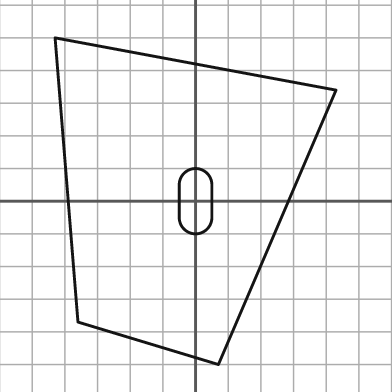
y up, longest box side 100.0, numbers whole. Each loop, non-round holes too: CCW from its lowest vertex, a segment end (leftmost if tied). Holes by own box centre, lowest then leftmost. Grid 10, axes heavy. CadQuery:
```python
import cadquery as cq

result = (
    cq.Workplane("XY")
    .moveTo(7.0, -50.0)
    .lineTo(43.0, 34.0)
    .lineTo(-43.0, 50.0)
    .lineTo(-36.0, -37.0)
    .close()
    .moveTo(-5.0, -5.0)
    .threePointArc((0.0, -10.0), (5.0, -5.0))
    .lineTo(5.0, 5.0)
    .threePointArc((0.0, 10.0), (-5.0, 5.0))
    .close()
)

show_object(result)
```